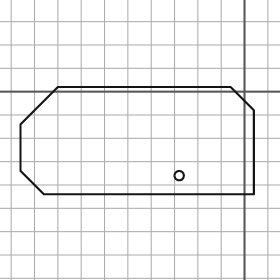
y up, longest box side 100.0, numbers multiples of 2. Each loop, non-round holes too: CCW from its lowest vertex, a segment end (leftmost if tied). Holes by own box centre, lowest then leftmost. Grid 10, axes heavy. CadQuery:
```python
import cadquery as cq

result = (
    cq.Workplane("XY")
    .moveTo(-86.0, -44.0)
    .lineTo(4.0, -44.0)
    .lineTo(4.0, -8.0)
    .lineTo(-6.0, 2.0)
    .lineTo(-80.0, 2.0)
    .lineTo(-96.0, -14.0)
    .lineTo(-96.0, -34.0)
    .close()
    .moveTo(-28.0, -36.0)
    .circle(2.0)
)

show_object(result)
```